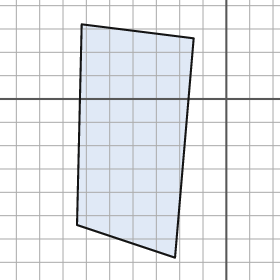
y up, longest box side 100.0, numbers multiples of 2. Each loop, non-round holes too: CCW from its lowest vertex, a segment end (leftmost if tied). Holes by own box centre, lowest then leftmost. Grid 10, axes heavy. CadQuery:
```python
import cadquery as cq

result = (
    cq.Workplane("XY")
    .moveTo(-22.0, -68.0)
    .lineTo(-14.0, 26.0)
    .lineTo(-62.0, 32.0)
    .lineTo(-64.0, -54.0)
    .close()
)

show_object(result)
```